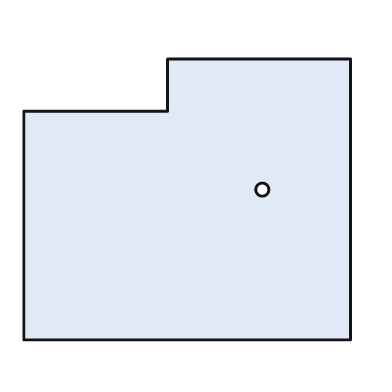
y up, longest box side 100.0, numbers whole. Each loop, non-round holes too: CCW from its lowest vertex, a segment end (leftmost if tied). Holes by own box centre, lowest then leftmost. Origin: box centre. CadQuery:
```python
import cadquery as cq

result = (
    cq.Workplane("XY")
    .moveTo(-50.0, -43.0)
    .lineTo(50.0, -43.0)
    .lineTo(50.0, 43.0)
    .lineTo(-6.0, 43.0)
    .lineTo(-6.0, 27.0)
    .lineTo(-50.0, 27.0)
    .close()
    .moveTo(23.0, 3.0)
    .circle(2.0)
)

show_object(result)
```